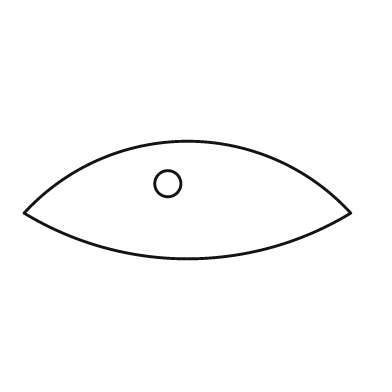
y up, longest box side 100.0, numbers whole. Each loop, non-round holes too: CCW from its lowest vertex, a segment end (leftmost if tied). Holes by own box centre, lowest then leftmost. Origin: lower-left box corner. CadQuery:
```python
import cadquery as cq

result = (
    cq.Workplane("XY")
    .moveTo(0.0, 14.0)
    .threePointArc((50.0, 0.0), (100.0, 14.0))
    .threePointArc((50.0, 36.0), (0.0, 14.0))
    .close()
    .moveTo(44.0, 23.0)
    .circle(4.0)
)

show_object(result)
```